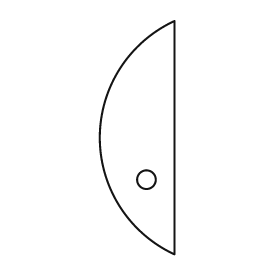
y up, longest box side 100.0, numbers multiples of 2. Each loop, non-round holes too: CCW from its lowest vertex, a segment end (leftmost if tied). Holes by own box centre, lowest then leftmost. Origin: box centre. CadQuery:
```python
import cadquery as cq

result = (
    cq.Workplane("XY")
    .moveTo(16.0, -50.0)
    .lineTo(16.0, 50.0)
    .threePointArc((-16.0, 0.0), (16.0, -50.0))
    .close()
    .moveTo(4.0, -18.0)
    .circle(4.0)
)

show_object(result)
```